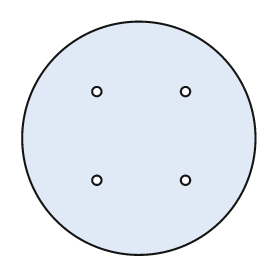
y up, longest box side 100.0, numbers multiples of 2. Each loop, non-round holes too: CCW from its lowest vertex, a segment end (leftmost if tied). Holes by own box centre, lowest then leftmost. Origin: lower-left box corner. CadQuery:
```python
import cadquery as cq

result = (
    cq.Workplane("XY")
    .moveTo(50.0, 50.0)
    .circle(50.0)
    .moveTo(32.0, 32.0)
    .circle(2.0)
    .moveTo(70.0, 32.0)
    .circle(2.0)
    .moveTo(32.0, 70.0)
    .circle(2.0)
    .moveTo(70.0, 70.0)
    .circle(2.0)
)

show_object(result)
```